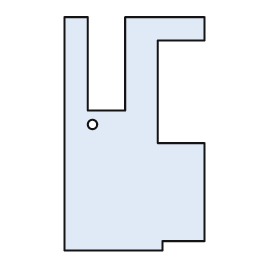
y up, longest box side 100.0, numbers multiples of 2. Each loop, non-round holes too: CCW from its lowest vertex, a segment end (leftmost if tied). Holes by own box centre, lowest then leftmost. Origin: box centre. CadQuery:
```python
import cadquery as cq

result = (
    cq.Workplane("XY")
    .moveTo(-30.0, -50.0)
    .lineTo(12.0, -50.0)
    .lineTo(12.0, -46.0)
    .lineTo(30.0, -46.0)
    .lineTo(30.0, -4.0)
    .lineTo(10.0, -4.0)
    .lineTo(10.0, 40.0)
    .lineTo(30.0, 40.0)
    .lineTo(30.0, 50.0)
    .lineTo(-4.0, 50.0)
    .lineTo(-4.0, 10.0)
    .lineTo(-20.0, 10.0)
    .lineTo(-20.0, 50.0)
    .lineTo(-30.0, 50.0)
    .close()
    .moveTo(-18.0, 4.0)
    .circle(2.0)
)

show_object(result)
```